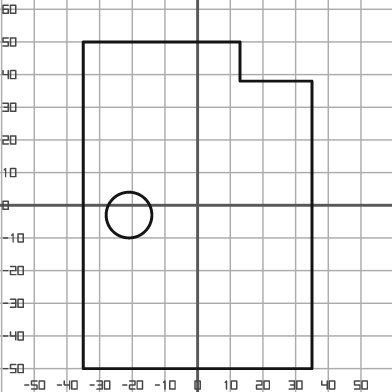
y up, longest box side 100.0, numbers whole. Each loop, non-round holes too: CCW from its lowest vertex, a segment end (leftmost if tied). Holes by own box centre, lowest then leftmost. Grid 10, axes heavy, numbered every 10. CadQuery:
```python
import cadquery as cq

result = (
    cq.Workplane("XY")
    .moveTo(-35.0, -50.0)
    .lineTo(35.0, -50.0)
    .lineTo(35.0, 38.0)
    .lineTo(13.0, 38.0)
    .lineTo(13.0, 50.0)
    .lineTo(-35.0, 50.0)
    .close()
    .moveTo(-21.0, -3.0)
    .circle(7.0)
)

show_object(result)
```